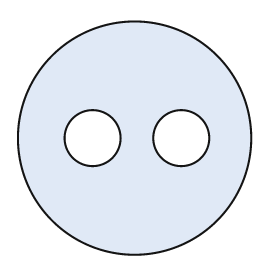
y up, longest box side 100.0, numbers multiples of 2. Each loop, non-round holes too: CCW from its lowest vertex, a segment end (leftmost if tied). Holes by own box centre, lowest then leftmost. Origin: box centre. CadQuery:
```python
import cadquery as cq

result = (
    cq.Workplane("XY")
    .moveTo(0.0, 0.0)
    .circle(50.0)
    .moveTo(-18.0, 0.0)
    .circle(12.0)
    .moveTo(20.0, 0.0)
    .circle(12.0)
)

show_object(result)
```